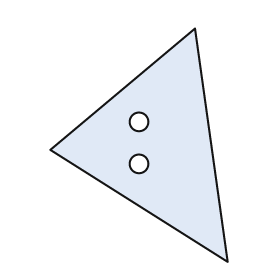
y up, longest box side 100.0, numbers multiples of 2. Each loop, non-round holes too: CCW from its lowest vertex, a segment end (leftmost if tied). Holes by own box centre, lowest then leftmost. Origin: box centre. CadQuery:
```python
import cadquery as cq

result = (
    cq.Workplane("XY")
    .moveTo(38.0, -50.0)
    .lineTo(24.0, 50.0)
    .lineTo(-38.0, -2.0)
    .close()
    .moveTo(0.0, -8.0)
    .circle(4.0)
    .moveTo(0.0, 10.0)
    .circle(4.0)
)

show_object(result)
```